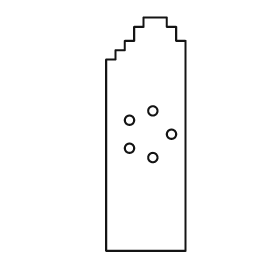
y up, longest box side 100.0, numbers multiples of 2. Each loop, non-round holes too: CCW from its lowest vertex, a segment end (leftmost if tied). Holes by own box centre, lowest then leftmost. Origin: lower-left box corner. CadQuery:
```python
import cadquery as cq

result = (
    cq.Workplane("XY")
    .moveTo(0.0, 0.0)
    .lineTo(34.0, 0.0)
    .lineTo(34.0, 90.0)
    .lineTo(30.0, 90.0)
    .lineTo(30.0, 96.0)
    .lineTo(26.0, 96.0)
    .lineTo(26.0, 100.0)
    .lineTo(16.0, 100.0)
    .lineTo(16.0, 96.0)
    .lineTo(12.0, 96.0)
    .lineTo(12.0, 90.0)
    .lineTo(8.0, 90.0)
    .lineTo(8.0, 86.0)
    .lineTo(4.0, 86.0)
    .lineTo(4.0, 82.0)
    .lineTo(0.0, 82.0)
    .close()
    .moveTo(20.0, 40.0)
    .circle(2.0)
    .moveTo(10.0, 44.0)
    .circle(2.0)
    .moveTo(28.0, 50.0)
    .circle(2.0)
    .moveTo(10.0, 56.0)
    .circle(2.0)
    .moveTo(20.0, 60.0)
    .circle(2.0)
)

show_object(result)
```